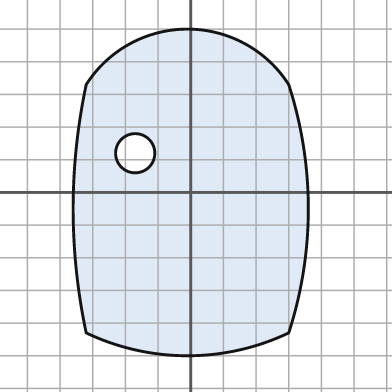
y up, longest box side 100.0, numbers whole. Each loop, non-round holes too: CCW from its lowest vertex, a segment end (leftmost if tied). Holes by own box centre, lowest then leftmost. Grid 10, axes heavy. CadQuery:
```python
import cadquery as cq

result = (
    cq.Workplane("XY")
    .moveTo(-32.0, -43.0)
    .threePointArc((-1.0, -50.0), (30.0, -43.0))
    .threePointArc((36.0, -5.0), (30.0, 33.0))
    .threePointArc((-1.0, 50.0), (-32.0, 33.0))
    .threePointArc((-36.0, -5.0), (-32.0, -43.0))
    .close()
    .moveTo(-17.0, 12.0)
    .circle(6.0)
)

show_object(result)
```